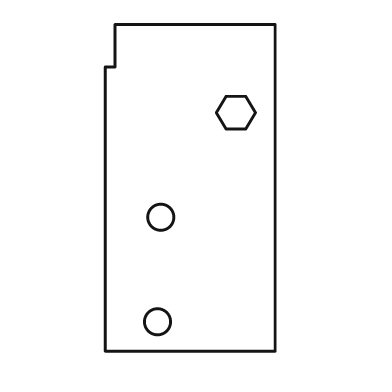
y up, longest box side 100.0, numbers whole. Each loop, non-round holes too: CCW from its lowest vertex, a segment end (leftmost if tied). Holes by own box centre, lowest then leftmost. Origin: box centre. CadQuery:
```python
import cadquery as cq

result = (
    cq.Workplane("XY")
    .moveTo(-26.0, -50.0)
    .lineTo(26.0, -50.0)
    .lineTo(26.0, 50.0)
    .lineTo(-23.0, 50.0)
    .lineTo(-23.0, 37.0)
    .lineTo(-26.0, 37.0)
    .close()
    .moveTo(-10.0, -41.0)
    .circle(4.0)
    .moveTo(-9.0, -9.0)
    .circle(4.0)
    .moveTo(11.0, 18.0)
    .lineTo(17.0, 18.0)
    .lineTo(20.0, 23.0)
    .lineTo(17.0, 28.0)
    .lineTo(11.0, 28.0)
    .lineTo(8.0, 23.0)
    .close()
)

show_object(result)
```